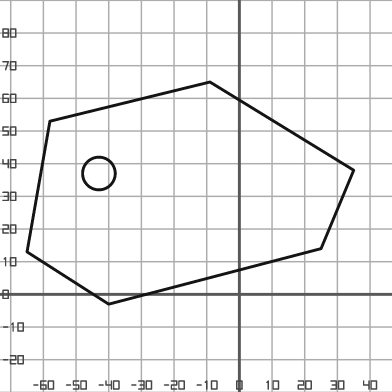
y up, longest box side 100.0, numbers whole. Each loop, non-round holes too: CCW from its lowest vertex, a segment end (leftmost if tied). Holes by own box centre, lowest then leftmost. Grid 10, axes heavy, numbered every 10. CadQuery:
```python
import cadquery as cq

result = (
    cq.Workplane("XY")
    .moveTo(-40.0, -3.0)
    .lineTo(25.0, 14.0)
    .lineTo(35.0, 38.0)
    .lineTo(-9.0, 65.0)
    .lineTo(-58.0, 53.0)
    .lineTo(-65.0, 13.0)
    .close()
    .moveTo(-43.0, 37.0)
    .circle(5.0)
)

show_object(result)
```